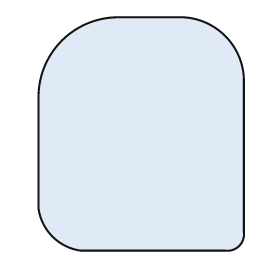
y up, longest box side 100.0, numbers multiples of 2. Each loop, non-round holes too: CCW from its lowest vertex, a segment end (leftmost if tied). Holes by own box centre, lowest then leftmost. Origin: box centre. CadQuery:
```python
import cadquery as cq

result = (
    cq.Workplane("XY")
    .moveTo(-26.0, -50.0)
    .lineTo(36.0, -50.0)
    .threePointArc((42.0, -48.0), (44.0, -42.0))
    .lineTo(44.0, 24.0)
    .threePointArc((36.0, 42.0), (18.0, 50.0))
    .lineTo(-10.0, 50.0)
    .threePointArc((-34.0, 40.0), (-44.0, 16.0))
    .lineTo(-44.0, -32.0)
    .threePointArc((-38.0, -44.0), (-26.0, -50.0))
    .close()
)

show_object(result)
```